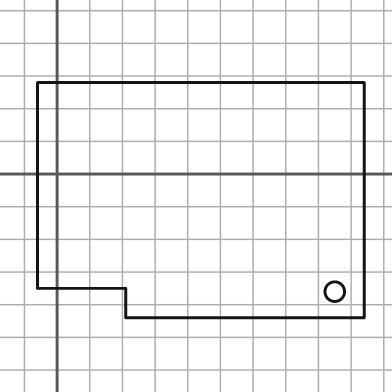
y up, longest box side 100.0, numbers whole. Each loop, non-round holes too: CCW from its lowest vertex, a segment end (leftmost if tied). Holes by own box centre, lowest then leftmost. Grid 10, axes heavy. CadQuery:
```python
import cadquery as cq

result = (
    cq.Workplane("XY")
    .moveTo(21.0, -44.0)
    .lineTo(94.0, -44.0)
    .lineTo(94.0, 28.0)
    .lineTo(-6.0, 28.0)
    .lineTo(-6.0, -35.0)
    .lineTo(21.0, -35.0)
    .close()
    .moveTo(85.0, -36.0)
    .circle(3.0)
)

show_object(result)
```